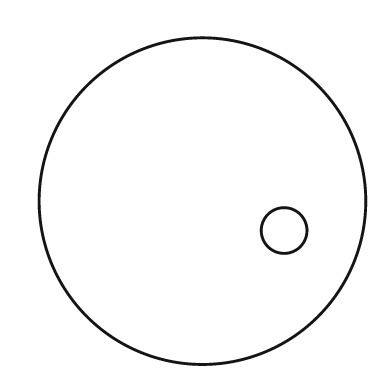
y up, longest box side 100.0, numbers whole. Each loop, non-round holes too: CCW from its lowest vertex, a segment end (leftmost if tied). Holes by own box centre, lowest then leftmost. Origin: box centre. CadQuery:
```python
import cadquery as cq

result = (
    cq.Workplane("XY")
    .moveTo(0.0, 0.0)
    .circle(50.0)
    .moveTo(25.0, -9.0)
    .circle(7.0)
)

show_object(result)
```